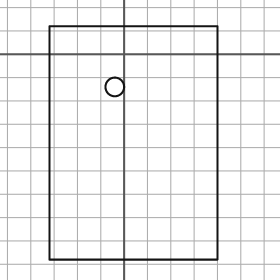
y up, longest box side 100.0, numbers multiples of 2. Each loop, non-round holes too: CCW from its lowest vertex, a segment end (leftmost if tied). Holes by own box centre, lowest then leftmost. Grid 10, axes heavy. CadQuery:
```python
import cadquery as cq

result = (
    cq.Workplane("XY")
    .moveTo(-32.0, -88.0)
    .lineTo(40.0, -88.0)
    .lineTo(40.0, 12.0)
    .lineTo(-32.0, 12.0)
    .close()
    .moveTo(-4.0, -14.0)
    .circle(4.0)
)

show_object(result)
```